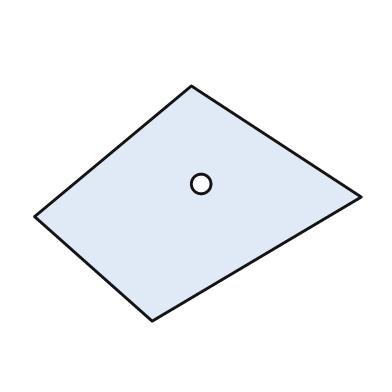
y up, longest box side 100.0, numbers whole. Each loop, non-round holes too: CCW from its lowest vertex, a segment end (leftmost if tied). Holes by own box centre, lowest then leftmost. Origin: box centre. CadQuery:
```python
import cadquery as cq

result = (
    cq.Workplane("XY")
    .moveTo(-14.0, -36.0)
    .lineTo(50.0, 2.0)
    .lineTo(-2.0, 36.0)
    .lineTo(-50.0, -4.0)
    .close()
    .moveTo(1.0, 6.0)
    .circle(3.0)
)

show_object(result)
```